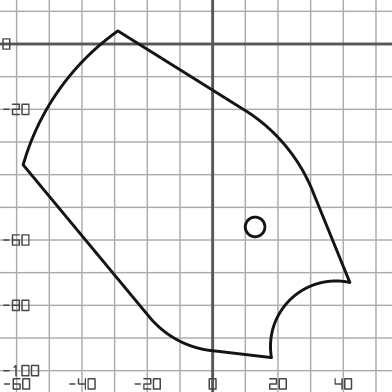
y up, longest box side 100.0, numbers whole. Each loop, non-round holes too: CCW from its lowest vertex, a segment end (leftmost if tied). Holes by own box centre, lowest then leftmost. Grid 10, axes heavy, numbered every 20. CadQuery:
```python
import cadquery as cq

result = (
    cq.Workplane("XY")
    .moveTo(18.0, -96.0)
    .threePointArc((24.0, -78.0), (42.0, -73.0))
    .lineTo(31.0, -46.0)
    .threePointArc((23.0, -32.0), (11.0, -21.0))
    .lineTo(-29.0, 4.0)
    .threePointArc((-47.0, -14.0), (-58.0, -37.0))
    .lineTo(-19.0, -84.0)
    .threePointArc((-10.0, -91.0), (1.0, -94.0))
    .close()
    .moveTo(13.0, -56.0)
    .circle(3.0)
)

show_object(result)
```